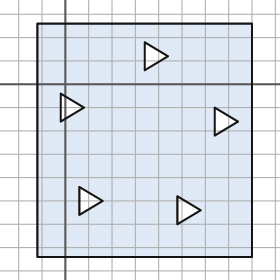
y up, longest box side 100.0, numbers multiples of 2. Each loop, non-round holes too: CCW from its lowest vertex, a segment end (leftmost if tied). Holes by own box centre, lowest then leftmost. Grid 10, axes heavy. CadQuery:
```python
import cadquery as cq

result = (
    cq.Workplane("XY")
    .moveTo(-12.0, -74.0)
    .lineTo(80.0, -74.0)
    .lineTo(80.0, 26.0)
    .lineTo(-12.0, 26.0)
    .close()
    .moveTo(48.0, -60.0)
    .lineTo(58.0, -54.0)
    .lineTo(48.0, -48.0)
    .close()
    .moveTo(6.0, -56.0)
    .lineTo(16.0, -50.0)
    .lineTo(6.0, -44.0)
    .close()
    .moveTo(64.0, -22.0)
    .lineTo(74.0, -16.0)
    .lineTo(64.0, -10.0)
    .close()
    .moveTo(-2.0, -16.0)
    .lineTo(8.0, -10.0)
    .lineTo(-2.0, -4.0)
    .close()
    .moveTo(34.0, 6.0)
    .lineTo(44.0, 12.0)
    .lineTo(34.0, 18.0)
    .close()
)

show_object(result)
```